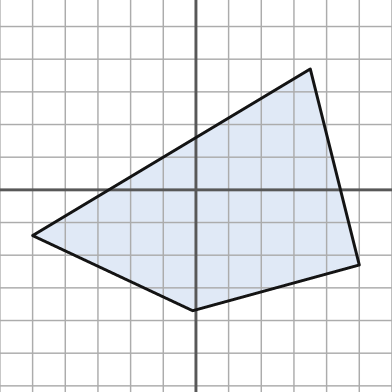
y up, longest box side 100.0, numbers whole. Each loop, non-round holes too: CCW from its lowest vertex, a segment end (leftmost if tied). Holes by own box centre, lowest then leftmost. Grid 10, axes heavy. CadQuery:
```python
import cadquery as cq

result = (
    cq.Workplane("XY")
    .moveTo(-1.0, -37.0)
    .lineTo(50.0, -23.0)
    .lineTo(35.0, 37.0)
    .lineTo(-50.0, -14.0)
    .close()
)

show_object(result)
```